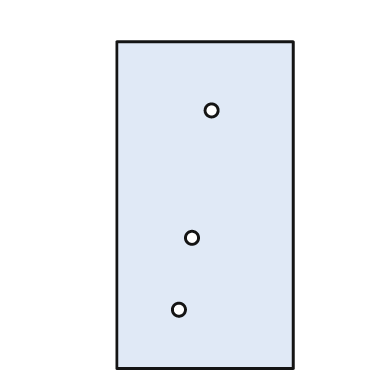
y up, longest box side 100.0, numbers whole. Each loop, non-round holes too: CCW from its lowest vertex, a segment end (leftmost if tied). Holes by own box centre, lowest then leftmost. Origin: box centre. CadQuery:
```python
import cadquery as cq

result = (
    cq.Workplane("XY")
    .moveTo(-27.0, -50.0)
    .lineTo(27.0, -50.0)
    .lineTo(27.0, 50.0)
    .lineTo(-27.0, 50.0)
    .close()
    .moveTo(-8.0, -32.0)
    .circle(2.0)
    .moveTo(-4.0, -10.0)
    .circle(2.0)
    .moveTo(2.0, 29.0)
    .circle(2.0)
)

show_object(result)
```